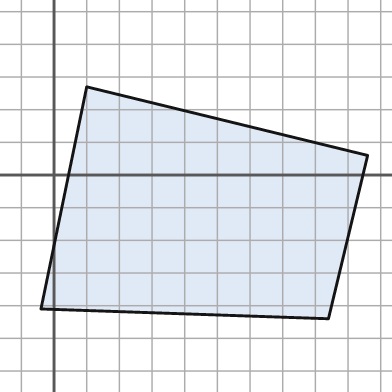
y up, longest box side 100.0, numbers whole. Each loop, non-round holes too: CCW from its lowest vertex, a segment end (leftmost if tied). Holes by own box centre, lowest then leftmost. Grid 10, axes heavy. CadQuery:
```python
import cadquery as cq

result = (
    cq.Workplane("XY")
    .moveTo(84.0, -44.0)
    .lineTo(96.0, 6.0)
    .lineTo(10.0, 27.0)
    .lineTo(-4.0, -41.0)
    .close()
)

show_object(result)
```